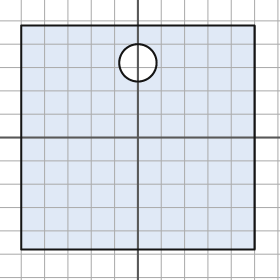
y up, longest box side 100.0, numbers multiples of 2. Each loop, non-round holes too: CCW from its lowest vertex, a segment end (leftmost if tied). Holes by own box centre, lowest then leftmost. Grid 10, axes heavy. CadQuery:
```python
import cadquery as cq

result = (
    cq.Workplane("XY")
    .moveTo(-50.0, -48.0)
    .lineTo(50.0, -48.0)
    .lineTo(50.0, 48.0)
    .lineTo(-50.0, 48.0)
    .close()
    .moveTo(0.0, 32.0)
    .circle(8.0)
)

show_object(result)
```